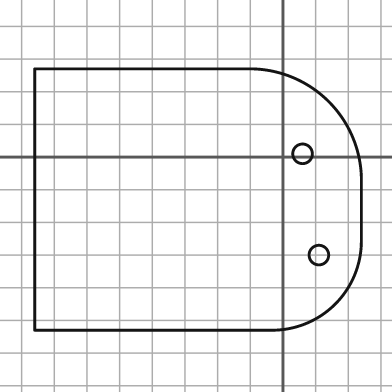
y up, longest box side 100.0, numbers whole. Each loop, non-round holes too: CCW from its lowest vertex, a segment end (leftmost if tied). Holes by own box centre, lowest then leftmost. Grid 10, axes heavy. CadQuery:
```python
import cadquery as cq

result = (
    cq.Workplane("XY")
    .moveTo(-76.0, -53.0)
    .lineTo(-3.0, -53.0)
    .threePointArc((16.0, -45.0), (24.0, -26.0))
    .lineTo(24.0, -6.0)
    .threePointArc((14.0, 17.0), (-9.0, 27.0))
    .lineTo(-76.0, 27.0)
    .close()
    .moveTo(11.0, -30.0)
    .circle(3.0)
    .moveTo(6.0, 1.0)
    .circle(3.0)
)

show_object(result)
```